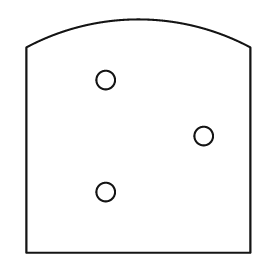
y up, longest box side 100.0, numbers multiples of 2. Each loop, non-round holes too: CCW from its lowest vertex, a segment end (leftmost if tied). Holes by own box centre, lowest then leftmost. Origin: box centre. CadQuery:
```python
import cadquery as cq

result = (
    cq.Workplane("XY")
    .moveTo(-48.0, -50.0)
    .lineTo(48.0, -50.0)
    .lineTo(48.0, 38.0)
    .threePointArc((0.0, 50.0), (-48.0, 38.0))
    .close()
    .moveTo(-14.0, -24.0)
    .circle(4.0)
    .moveTo(28.0, 0.0)
    .circle(4.0)
    .moveTo(-14.0, 24.0)
    .circle(4.0)
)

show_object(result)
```